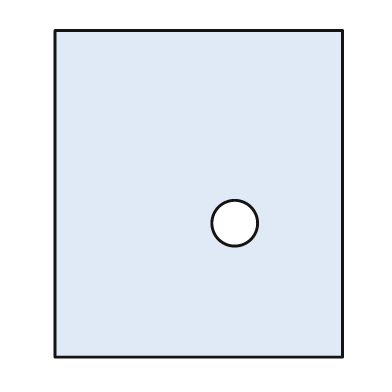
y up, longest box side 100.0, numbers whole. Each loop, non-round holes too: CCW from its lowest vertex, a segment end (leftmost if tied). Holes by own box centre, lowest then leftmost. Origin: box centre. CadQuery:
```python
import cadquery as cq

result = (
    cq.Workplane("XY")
    .moveTo(-44.0, -50.0)
    .lineTo(44.0, -50.0)
    .lineTo(44.0, 50.0)
    .lineTo(-44.0, 50.0)
    .close()
    .moveTo(11.0, -9.0)
    .circle(7.0)
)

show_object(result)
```